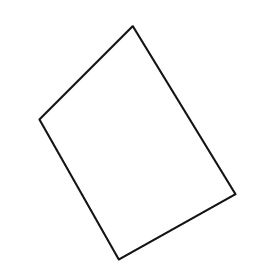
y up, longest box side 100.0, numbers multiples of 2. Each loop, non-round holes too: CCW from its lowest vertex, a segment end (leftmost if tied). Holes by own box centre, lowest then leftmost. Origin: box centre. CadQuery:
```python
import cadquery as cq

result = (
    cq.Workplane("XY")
    .moveTo(-8.0, -50.0)
    .lineTo(42.0, -22.0)
    .lineTo(-2.0, 50.0)
    .lineTo(-42.0, 10.0)
    .close()
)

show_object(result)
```